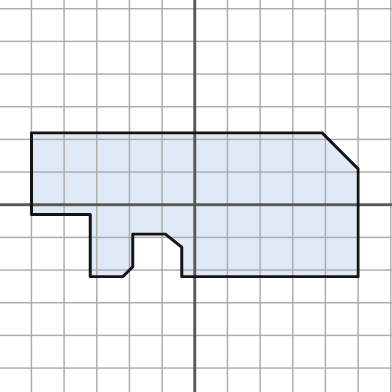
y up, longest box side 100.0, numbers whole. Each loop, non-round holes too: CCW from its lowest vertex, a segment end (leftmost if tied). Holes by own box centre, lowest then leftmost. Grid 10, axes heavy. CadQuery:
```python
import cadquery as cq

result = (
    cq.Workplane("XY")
    .moveTo(-32.0, -22.0)
    .lineTo(-22.0, -22.0)
    .lineTo(-19.0, -19.0)
    .lineTo(-19.0, -9.0)
    .lineTo(-9.0, -9.0)
    .lineTo(-4.0, -13.0)
    .lineTo(-4.0, -22.0)
    .lineTo(50.0, -22.0)
    .lineTo(50.0, 11.0)
    .lineTo(39.0, 22.0)
    .lineTo(-50.0, 22.0)
    .lineTo(-50.0, -3.0)
    .lineTo(-32.0, -3.0)
    .close()
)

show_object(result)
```